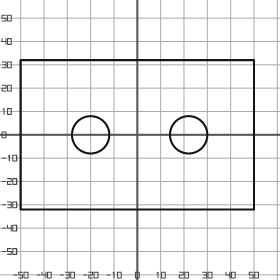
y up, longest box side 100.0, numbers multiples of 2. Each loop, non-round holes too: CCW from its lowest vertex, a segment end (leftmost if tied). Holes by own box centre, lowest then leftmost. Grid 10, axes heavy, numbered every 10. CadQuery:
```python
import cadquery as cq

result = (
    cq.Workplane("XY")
    .moveTo(-50.0, -32.0)
    .lineTo(50.0, -32.0)
    .lineTo(50.0, 32.0)
    .lineTo(-50.0, 32.0)
    .close()
    .moveTo(-20.0, 0.0)
    .circle(8.0)
    .moveTo(22.0, 0.0)
    .circle(8.0)
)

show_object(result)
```